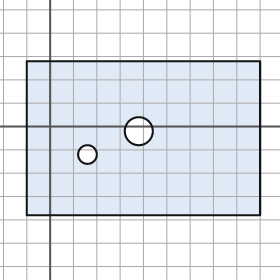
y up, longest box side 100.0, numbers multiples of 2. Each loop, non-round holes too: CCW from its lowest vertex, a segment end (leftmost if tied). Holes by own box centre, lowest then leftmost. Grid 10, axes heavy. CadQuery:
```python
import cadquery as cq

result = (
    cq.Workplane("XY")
    .moveTo(-10.0, -38.0)
    .lineTo(90.0, -38.0)
    .lineTo(90.0, 28.0)
    .lineTo(-10.0, 28.0)
    .close()
    .moveTo(16.0, -12.0)
    .circle(4.0)
    .moveTo(38.0, -2.0)
    .circle(6.0)
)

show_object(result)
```